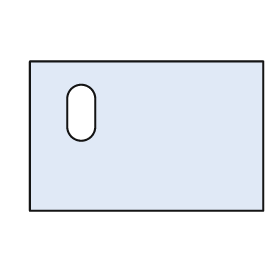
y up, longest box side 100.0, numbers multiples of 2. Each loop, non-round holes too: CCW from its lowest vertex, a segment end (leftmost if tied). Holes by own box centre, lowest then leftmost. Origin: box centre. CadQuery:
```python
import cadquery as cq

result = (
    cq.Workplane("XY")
    .moveTo(-50.0, -32.0)
    .lineTo(50.0, -32.0)
    .lineTo(50.0, 32.0)
    .lineTo(-50.0, 32.0)
    .close()
    .moveTo(-34.0, 4.0)
    .threePointArc((-28.0, -2.0), (-22.0, 4.0))
    .lineTo(-22.0, 16.0)
    .threePointArc((-28.0, 22.0), (-34.0, 16.0))
    .close()
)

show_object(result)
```